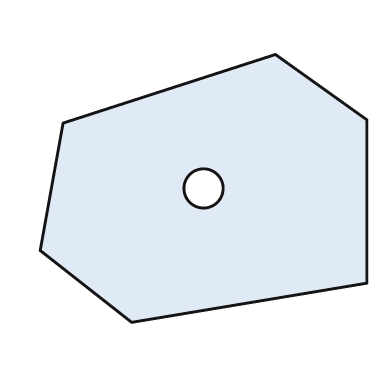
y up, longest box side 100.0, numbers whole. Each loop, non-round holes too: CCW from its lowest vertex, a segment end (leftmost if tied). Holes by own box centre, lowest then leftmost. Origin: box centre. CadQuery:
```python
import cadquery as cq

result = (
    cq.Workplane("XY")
    .moveTo(-22.0, -41.0)
    .lineTo(50.0, -29.0)
    .lineTo(50.0, 21.0)
    .lineTo(22.0, 41.0)
    .lineTo(-43.0, 20.0)
    .lineTo(-50.0, -19.0)
    .close()
    .moveTo(0.0, 0.0)
    .circle(6.0)
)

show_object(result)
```